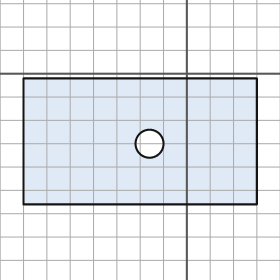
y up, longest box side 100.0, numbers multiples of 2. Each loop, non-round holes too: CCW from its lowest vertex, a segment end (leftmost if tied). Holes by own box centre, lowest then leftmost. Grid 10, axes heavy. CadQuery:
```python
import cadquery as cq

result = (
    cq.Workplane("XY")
    .moveTo(-70.0, -56.0)
    .lineTo(30.0, -56.0)
    .lineTo(30.0, -2.0)
    .lineTo(-70.0, -2.0)
    .close()
    .moveTo(-16.0, -30.0)
    .circle(6.0)
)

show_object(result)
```